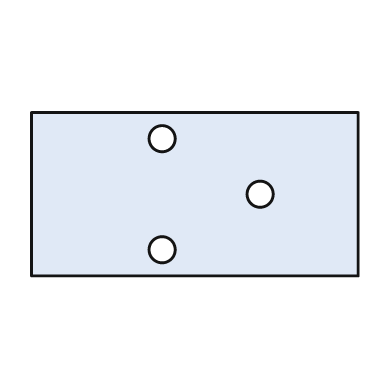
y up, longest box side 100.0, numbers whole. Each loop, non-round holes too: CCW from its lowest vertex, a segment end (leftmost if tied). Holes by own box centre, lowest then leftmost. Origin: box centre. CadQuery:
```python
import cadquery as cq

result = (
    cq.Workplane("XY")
    .moveTo(-50.0, -25.0)
    .lineTo(50.0, -25.0)
    .lineTo(50.0, 25.0)
    .lineTo(-50.0, 25.0)
    .close()
    .moveTo(-10.0, -17.0)
    .circle(4.0)
    .moveTo(20.0, 0.0)
    .circle(4.0)
    .moveTo(-10.0, 17.0)
    .circle(4.0)
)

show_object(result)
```